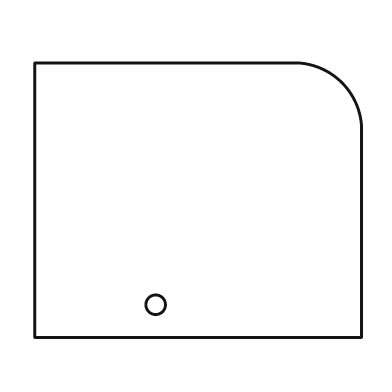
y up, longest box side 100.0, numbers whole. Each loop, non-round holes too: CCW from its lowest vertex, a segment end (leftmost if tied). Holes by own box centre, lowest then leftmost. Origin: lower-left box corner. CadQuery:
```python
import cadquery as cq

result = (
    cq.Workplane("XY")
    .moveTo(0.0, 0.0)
    .lineTo(100.0, 0.0)
    .lineTo(100.0, 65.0)
    .threePointArc((94.0, 78.0), (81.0, 84.0))
    .lineTo(0.0, 84.0)
    .close()
    .moveTo(37.0, 10.0)
    .circle(3.0)
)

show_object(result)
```